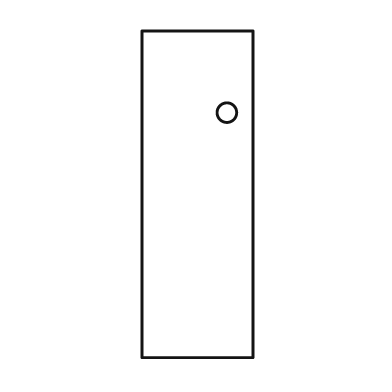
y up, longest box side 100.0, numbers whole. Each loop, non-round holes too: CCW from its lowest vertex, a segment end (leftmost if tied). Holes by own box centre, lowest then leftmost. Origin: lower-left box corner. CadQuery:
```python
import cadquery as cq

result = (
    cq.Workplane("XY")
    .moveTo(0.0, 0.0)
    .lineTo(34.0, 0.0)
    .lineTo(34.0, 100.0)
    .lineTo(0.0, 100.0)
    .close()
    .moveTo(26.0, 75.0)
    .circle(3.0)
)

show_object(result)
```